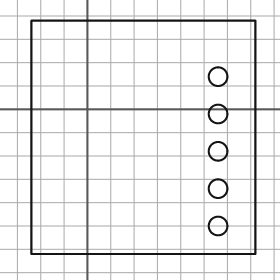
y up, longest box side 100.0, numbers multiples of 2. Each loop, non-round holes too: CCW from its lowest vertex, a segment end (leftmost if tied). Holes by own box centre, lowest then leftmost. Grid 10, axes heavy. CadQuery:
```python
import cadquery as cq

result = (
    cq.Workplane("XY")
    .moveTo(-24.0, -62.0)
    .lineTo(72.0, -62.0)
    .lineTo(72.0, 38.0)
    .lineTo(-24.0, 38.0)
    .close()
    .moveTo(56.0, -50.0)
    .circle(4.0)
    .moveTo(56.0, -34.0)
    .circle(4.0)
    .moveTo(56.0, -18.0)
    .circle(4.0)
    .moveTo(56.0, -2.0)
    .circle(4.0)
    .moveTo(56.0, 14.0)
    .circle(4.0)
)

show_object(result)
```